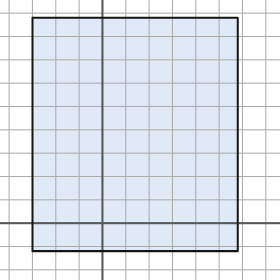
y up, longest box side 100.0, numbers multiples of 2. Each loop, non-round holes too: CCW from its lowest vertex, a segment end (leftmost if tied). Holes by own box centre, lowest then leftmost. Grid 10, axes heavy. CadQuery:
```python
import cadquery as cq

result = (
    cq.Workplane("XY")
    .moveTo(-30.0, -12.0)
    .lineTo(58.0, -12.0)
    .lineTo(58.0, 88.0)
    .lineTo(-30.0, 88.0)
    .close()
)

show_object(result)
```